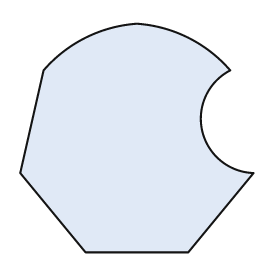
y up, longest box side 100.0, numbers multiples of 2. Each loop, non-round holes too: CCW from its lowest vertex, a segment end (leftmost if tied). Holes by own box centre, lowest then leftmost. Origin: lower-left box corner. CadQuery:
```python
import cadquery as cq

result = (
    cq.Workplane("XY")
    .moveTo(28.0, 0.0)
    .lineTo(72.0, 0.0)
    .lineTo(100.0, 34.0)
    .threePointArc((78.0, 52.0), (90.0, 78.0))
    .threePointArc((72.0, 92.0), (50.0, 98.0))
    .threePointArc((28.0, 92.0), (10.0, 78.0))
    .lineTo(0.0, 34.0)
    .close()
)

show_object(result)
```